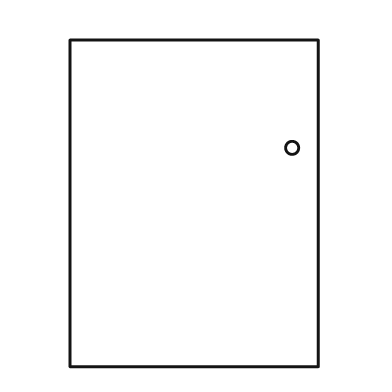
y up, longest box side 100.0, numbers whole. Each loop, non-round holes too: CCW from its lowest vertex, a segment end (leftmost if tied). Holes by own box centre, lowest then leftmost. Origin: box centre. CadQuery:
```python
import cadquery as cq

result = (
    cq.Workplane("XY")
    .moveTo(-38.0, -50.0)
    .lineTo(38.0, -50.0)
    .lineTo(38.0, 50.0)
    .lineTo(-38.0, 50.0)
    .close()
    .moveTo(30.0, 17.0)
    .circle(2.0)
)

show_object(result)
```